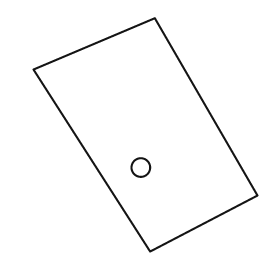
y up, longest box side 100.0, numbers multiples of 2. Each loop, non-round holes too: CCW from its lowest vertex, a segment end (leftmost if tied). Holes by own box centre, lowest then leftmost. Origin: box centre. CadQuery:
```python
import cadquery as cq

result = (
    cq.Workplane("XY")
    .moveTo(2.0, -50.0)
    .lineTo(48.0, -26.0)
    .lineTo(4.0, 50.0)
    .lineTo(-48.0, 28.0)
    .close()
    .moveTo(-2.0, -14.0)
    .circle(4.0)
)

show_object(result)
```